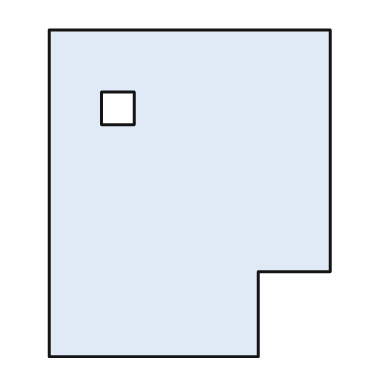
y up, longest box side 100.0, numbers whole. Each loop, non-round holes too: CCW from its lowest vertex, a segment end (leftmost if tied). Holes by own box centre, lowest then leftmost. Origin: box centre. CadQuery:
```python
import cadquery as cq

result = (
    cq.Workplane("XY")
    .moveTo(-43.0, -50.0)
    .lineTo(21.0, -50.0)
    .lineTo(21.0, -24.0)
    .lineTo(43.0, -24.0)
    .lineTo(43.0, 50.0)
    .lineTo(-43.0, 50.0)
    .close()
    .moveTo(-27.0, 21.0)
    .lineTo(-17.0, 21.0)
    .lineTo(-17.0, 31.0)
    .lineTo(-27.0, 31.0)
    .close()
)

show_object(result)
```